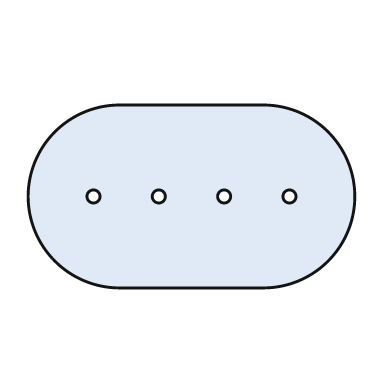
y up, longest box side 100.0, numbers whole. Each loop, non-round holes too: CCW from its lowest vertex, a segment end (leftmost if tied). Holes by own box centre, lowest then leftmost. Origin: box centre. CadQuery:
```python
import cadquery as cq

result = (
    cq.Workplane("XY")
    .moveTo(-22.0, -28.0)
    .lineTo(22.0, -28.0)
    .threePointArc((50.0, 0.0), (22.0, 28.0))
    .lineTo(-22.0, 28.0)
    .threePointArc((-50.0, 0.0), (-22.0, -28.0))
    .close()
    .moveTo(-30.0, 0.0)
    .circle(2.0)
    .moveTo(-10.0, 0.0)
    .circle(2.0)
    .moveTo(10.0, 0.0)
    .circle(2.0)
    .moveTo(30.0, 0.0)
    .circle(2.0)
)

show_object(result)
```